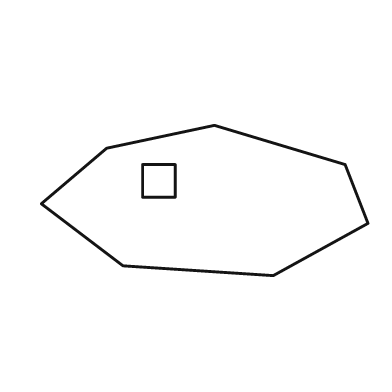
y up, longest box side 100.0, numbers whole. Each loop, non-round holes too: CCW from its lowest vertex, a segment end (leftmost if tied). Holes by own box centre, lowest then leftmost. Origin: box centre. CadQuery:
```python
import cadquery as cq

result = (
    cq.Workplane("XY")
    .moveTo(21.0, -23.0)
    .lineTo(50.0, -7.0)
    .lineTo(43.0, 11.0)
    .lineTo(3.0, 23.0)
    .lineTo(-30.0, 16.0)
    .lineTo(-50.0, -1.0)
    .lineTo(-25.0, -20.0)
    .close()
    .moveTo(-19.0, 1.0)
    .lineTo(-9.0, 1.0)
    .lineTo(-9.0, 11.0)
    .lineTo(-19.0, 11.0)
    .close()
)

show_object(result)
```